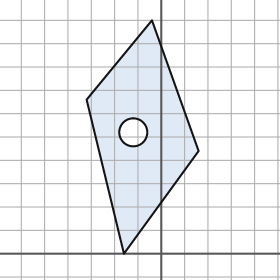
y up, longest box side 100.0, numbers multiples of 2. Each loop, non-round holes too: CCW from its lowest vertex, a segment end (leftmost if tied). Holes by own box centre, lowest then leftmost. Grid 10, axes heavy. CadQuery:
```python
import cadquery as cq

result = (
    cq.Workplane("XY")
    .moveTo(-16.0, 0.0)
    .lineTo(16.0, 44.0)
    .lineTo(-4.0, 100.0)
    .lineTo(-32.0, 66.0)
    .close()
    .moveTo(-12.0, 52.0)
    .circle(6.0)
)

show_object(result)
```